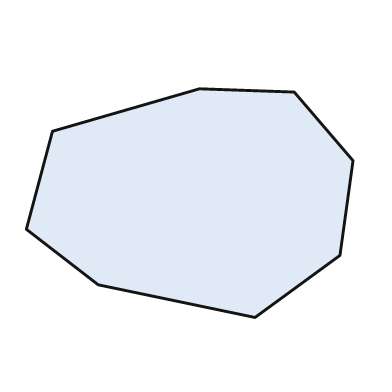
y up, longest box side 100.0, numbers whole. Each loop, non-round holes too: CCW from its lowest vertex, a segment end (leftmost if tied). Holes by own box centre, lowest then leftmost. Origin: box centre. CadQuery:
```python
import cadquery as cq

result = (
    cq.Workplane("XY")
    .moveTo(20.0, -35.0)
    .lineTo(46.0, -16.0)
    .lineTo(50.0, 13.0)
    .lineTo(32.0, 34.0)
    .lineTo(3.0, 35.0)
    .lineTo(-42.0, 22.0)
    .lineTo(-50.0, -8.0)
    .lineTo(-28.0, -25.0)
    .close()
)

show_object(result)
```